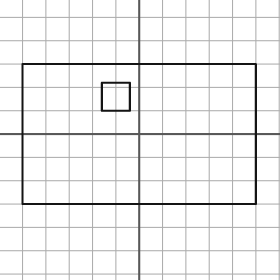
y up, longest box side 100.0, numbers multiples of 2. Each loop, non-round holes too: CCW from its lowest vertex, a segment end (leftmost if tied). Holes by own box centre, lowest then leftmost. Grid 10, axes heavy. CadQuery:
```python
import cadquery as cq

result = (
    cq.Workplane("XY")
    .moveTo(-50.0, -30.0)
    .lineTo(50.0, -30.0)
    .lineTo(50.0, 30.0)
    .lineTo(-50.0, 30.0)
    .close()
    .moveTo(-16.0, 10.0)
    .lineTo(-4.0, 10.0)
    .lineTo(-4.0, 22.0)
    .lineTo(-16.0, 22.0)
    .close()
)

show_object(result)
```